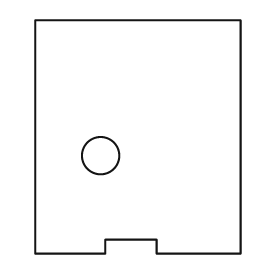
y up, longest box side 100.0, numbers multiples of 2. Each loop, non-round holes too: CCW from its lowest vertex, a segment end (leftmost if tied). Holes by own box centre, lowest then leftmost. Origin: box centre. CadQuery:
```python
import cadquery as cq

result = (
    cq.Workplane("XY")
    .moveTo(-44.0, -50.0)
    .lineTo(-14.0, -50.0)
    .lineTo(-14.0, -44.0)
    .lineTo(8.0, -44.0)
    .lineTo(8.0, -50.0)
    .lineTo(44.0, -50.0)
    .lineTo(44.0, 50.0)
    .lineTo(-44.0, 50.0)
    .close()
    .moveTo(-16.0, -8.0)
    .circle(8.0)
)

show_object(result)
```